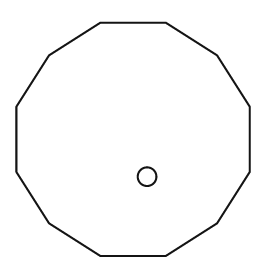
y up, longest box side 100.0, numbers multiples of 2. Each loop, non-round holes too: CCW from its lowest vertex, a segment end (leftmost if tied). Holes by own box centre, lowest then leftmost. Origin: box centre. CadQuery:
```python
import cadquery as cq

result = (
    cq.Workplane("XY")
    .moveTo(-14.0, -50.0)
    .lineTo(14.0, -50.0)
    .lineTo(36.0, -36.0)
    .lineTo(50.0, -14.0)
    .lineTo(50.0, 14.0)
    .lineTo(36.0, 36.0)
    .lineTo(14.0, 50.0)
    .lineTo(-14.0, 50.0)
    .lineTo(-36.0, 36.0)
    .lineTo(-50.0, 14.0)
    .lineTo(-50.0, -14.0)
    .lineTo(-36.0, -36.0)
    .close()
    .moveTo(6.0, -16.0)
    .circle(4.0)
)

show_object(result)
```